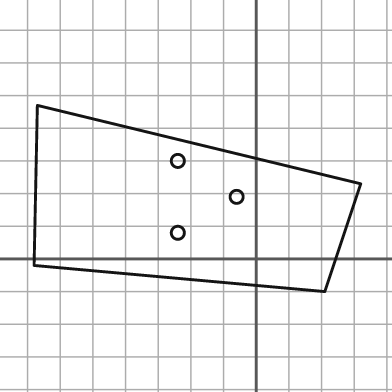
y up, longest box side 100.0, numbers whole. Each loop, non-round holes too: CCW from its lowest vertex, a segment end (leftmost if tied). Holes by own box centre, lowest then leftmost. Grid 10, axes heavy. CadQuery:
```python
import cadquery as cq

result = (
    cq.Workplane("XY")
    .moveTo(21.0, -10.0)
    .lineTo(32.0, 23.0)
    .lineTo(-67.0, 47.0)
    .lineTo(-68.0, -2.0)
    .close()
    .moveTo(-24.0, 8.0)
    .circle(2.0)
    .moveTo(-6.0, 19.0)
    .circle(2.0)
    .moveTo(-24.0, 30.0)
    .circle(2.0)
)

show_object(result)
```